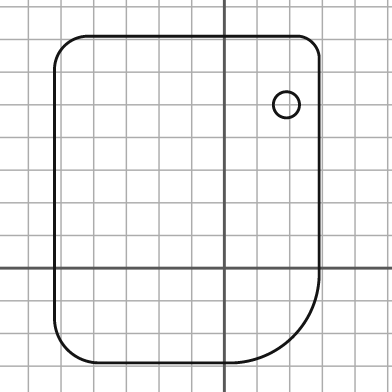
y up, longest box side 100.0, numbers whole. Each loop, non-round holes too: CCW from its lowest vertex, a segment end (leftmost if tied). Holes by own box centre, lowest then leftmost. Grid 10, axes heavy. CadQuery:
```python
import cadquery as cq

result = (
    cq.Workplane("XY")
    .moveTo(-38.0, -29.0)
    .lineTo(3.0, -29.0)
    .threePointArc((21.0, -21.0), (29.0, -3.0))
    .lineTo(29.0, 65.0)
    .threePointArc((27.0, 69.0), (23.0, 71.0))
    .lineTo(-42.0, 71.0)
    .threePointArc((-49.0, 68.0), (-52.0, 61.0))
    .lineTo(-52.0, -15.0)
    .threePointArc((-48.0, -25.0), (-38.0, -29.0))
    .close()
    .moveTo(19.0, 50.0)
    .circle(4.0)
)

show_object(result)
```